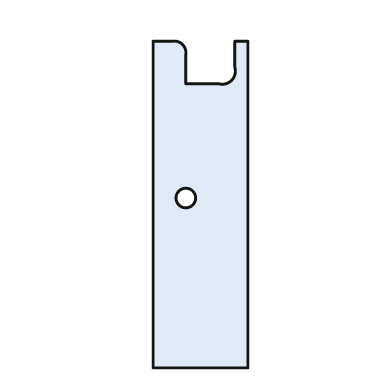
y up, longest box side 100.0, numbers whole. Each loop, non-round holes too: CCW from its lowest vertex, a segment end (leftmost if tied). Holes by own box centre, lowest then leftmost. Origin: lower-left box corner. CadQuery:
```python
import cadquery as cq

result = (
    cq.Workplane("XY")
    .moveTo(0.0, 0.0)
    .lineTo(29.0, 0.0)
    .lineTo(29.0, 100.0)
    .lineTo(25.0, 100.0)
    .lineTo(25.0, 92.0)
    .threePointArc((24.0, 88.0), (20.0, 87.0))
    .lineTo(10.0, 87.0)
    .lineTo(10.0, 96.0)
    .threePointArc((9.0, 99.0), (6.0, 100.0))
    .lineTo(0.0, 100.0)
    .close()
    .moveTo(10.0, 52.0)
    .circle(3.0)
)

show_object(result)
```